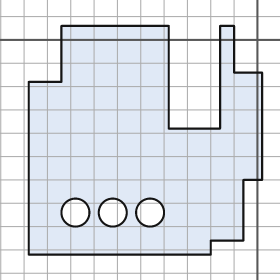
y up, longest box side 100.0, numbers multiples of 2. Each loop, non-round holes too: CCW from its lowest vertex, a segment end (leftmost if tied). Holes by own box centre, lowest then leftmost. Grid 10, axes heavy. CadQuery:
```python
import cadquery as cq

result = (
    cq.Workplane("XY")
    .moveTo(-98.0, -92.0)
    .lineTo(-20.0, -92.0)
    .lineTo(-20.0, -86.0)
    .lineTo(-6.0, -86.0)
    .lineTo(-6.0, -60.0)
    .lineTo(2.0, -60.0)
    .lineTo(2.0, -14.0)
    .lineTo(-10.0, -14.0)
    .lineTo(-10.0, 6.0)
    .lineTo(-16.0, 6.0)
    .lineTo(-16.0, -38.0)
    .lineTo(-38.0, -38.0)
    .lineTo(-38.0, 6.0)
    .lineTo(-84.0, 6.0)
    .lineTo(-84.0, -18.0)
    .lineTo(-98.0, -18.0)
    .close()
    .moveTo(-78.0, -74.0)
    .circle(6.0)
    .moveTo(-62.0, -74.0)
    .circle(6.0)
    .moveTo(-46.0, -74.0)
    .circle(6.0)
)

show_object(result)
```